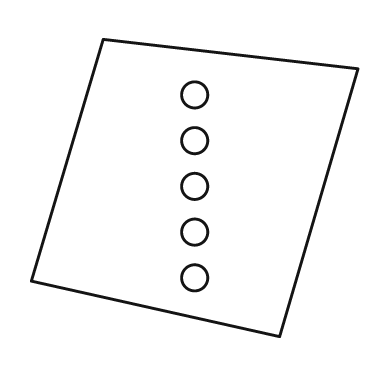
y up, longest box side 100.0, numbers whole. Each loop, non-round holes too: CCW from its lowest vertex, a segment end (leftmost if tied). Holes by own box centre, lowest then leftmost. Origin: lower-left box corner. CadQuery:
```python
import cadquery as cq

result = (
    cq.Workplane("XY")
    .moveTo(76.0, 0.0)
    .lineTo(100.0, 82.0)
    .lineTo(22.0, 91.0)
    .lineTo(0.0, 17.0)
    .close()
    .moveTo(50.0, 18.0)
    .circle(4.0)
    .moveTo(50.0, 32.0)
    .circle(4.0)
    .moveTo(50.0, 46.0)
    .circle(4.0)
    .moveTo(50.0, 60.0)
    .circle(4.0)
    .moveTo(50.0, 74.0)
    .circle(4.0)
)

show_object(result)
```